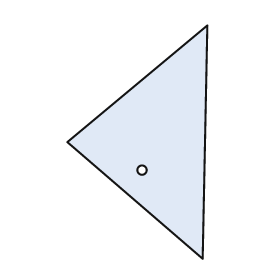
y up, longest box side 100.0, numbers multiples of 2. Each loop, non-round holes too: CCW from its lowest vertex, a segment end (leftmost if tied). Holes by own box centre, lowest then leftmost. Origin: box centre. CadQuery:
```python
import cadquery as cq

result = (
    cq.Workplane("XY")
    .moveTo(28.0, -50.0)
    .lineTo(30.0, 50.0)
    .lineTo(-30.0, 0.0)
    .close()
    .moveTo(2.0, -12.0)
    .circle(2.0)
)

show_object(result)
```